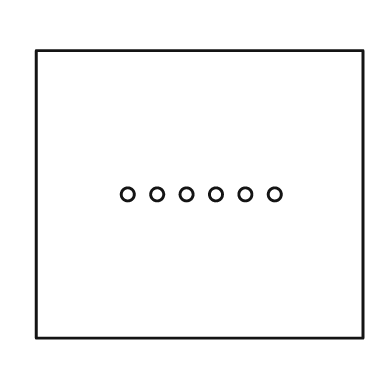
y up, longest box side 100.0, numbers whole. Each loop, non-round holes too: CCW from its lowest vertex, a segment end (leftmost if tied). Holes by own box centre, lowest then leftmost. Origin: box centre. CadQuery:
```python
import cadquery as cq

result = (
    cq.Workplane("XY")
    .moveTo(-50.0, -44.0)
    .lineTo(50.0, -44.0)
    .lineTo(50.0, 44.0)
    .lineTo(-50.0, 44.0)
    .close()
    .moveTo(-22.0, 0.0)
    .circle(2.0)
    .moveTo(-13.0, 0.0)
    .circle(2.0)
    .moveTo(-4.0, 0.0)
    .circle(2.0)
    .moveTo(5.0, 0.0)
    .circle(2.0)
    .moveTo(14.0, 0.0)
    .circle(2.0)
    .moveTo(23.0, 0.0)
    .circle(2.0)
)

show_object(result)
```